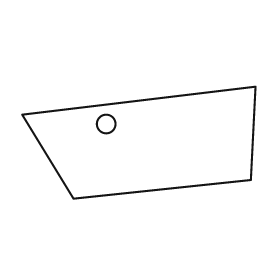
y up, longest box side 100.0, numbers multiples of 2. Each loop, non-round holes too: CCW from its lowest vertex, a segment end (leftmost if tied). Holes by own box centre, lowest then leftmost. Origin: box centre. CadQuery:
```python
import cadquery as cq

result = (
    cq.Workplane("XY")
    .moveTo(-28.0, -24.0)
    .lineTo(48.0, -16.0)
    .lineTo(50.0, 24.0)
    .lineTo(-50.0, 12.0)
    .close()
    .moveTo(-14.0, 8.0)
    .circle(4.0)
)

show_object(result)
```